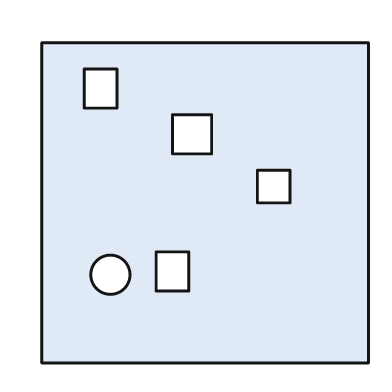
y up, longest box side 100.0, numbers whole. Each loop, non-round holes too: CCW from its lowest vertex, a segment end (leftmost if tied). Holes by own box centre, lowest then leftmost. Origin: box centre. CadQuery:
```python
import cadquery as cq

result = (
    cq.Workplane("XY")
    .moveTo(-50.0, -49.0)
    .lineTo(50.0, -49.0)
    .lineTo(50.0, 49.0)
    .lineTo(-50.0, 49.0)
    .close()
    .moveTo(-29.0, -22.0)
    .circle(6.0)
    .moveTo(-15.0, -27.0)
    .lineTo(-5.0, -27.0)
    .lineTo(-5.0, -15.0)
    .lineTo(-15.0, -15.0)
    .close()
    .moveTo(16.0, 0.0)
    .lineTo(26.0, 0.0)
    .lineTo(26.0, 10.0)
    .lineTo(16.0, 10.0)
    .close()
    .moveTo(-10.0, 15.0)
    .lineTo(2.0, 15.0)
    .lineTo(2.0, 27.0)
    .lineTo(-10.0, 27.0)
    .close()
    .moveTo(-37.0, 29.0)
    .lineTo(-27.0, 29.0)
    .lineTo(-27.0, 41.0)
    .lineTo(-37.0, 41.0)
    .close()
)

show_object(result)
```